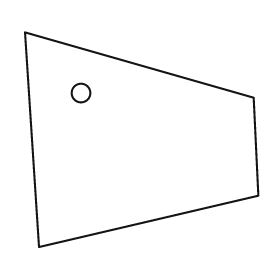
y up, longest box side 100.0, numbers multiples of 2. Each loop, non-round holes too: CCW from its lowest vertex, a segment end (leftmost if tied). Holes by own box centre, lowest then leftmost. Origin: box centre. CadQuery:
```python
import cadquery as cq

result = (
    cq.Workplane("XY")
    .moveTo(-44.0, -46.0)
    .lineTo(50.0, -24.0)
    .lineTo(48.0, 18.0)
    .lineTo(-50.0, 46.0)
    .close()
    .moveTo(-26.0, 20.0)
    .circle(4.0)
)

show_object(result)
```